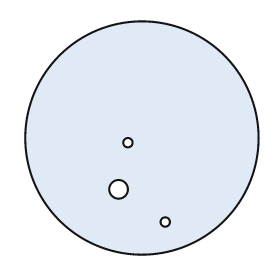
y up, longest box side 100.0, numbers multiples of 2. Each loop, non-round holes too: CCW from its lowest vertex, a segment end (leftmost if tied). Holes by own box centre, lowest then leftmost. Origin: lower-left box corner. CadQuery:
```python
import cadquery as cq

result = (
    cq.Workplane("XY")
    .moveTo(50.0, 50.0)
    .circle(50.0)
    .moveTo(60.0, 14.0)
    .circle(2.0)
    .moveTo(40.0, 28.0)
    .circle(4.0)
    .moveTo(44.0, 48.0)
    .circle(2.0)
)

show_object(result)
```